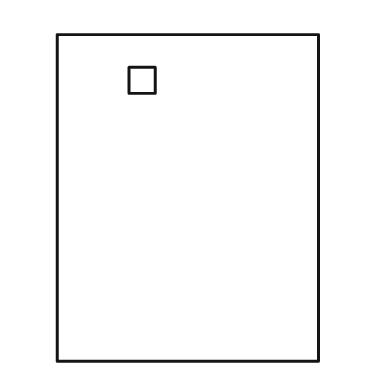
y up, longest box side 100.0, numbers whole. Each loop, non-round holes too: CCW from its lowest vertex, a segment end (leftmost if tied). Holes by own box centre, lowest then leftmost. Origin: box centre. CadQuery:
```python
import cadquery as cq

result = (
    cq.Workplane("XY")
    .moveTo(-40.0, -50.0)
    .lineTo(40.0, -50.0)
    .lineTo(40.0, 50.0)
    .lineTo(-40.0, 50.0)
    .close()
    .moveTo(-18.0, 32.0)
    .lineTo(-10.0, 32.0)
    .lineTo(-10.0, 40.0)
    .lineTo(-18.0, 40.0)
    .close()
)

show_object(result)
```